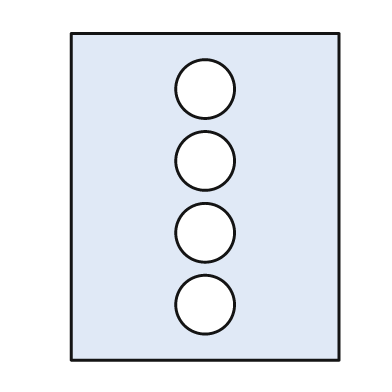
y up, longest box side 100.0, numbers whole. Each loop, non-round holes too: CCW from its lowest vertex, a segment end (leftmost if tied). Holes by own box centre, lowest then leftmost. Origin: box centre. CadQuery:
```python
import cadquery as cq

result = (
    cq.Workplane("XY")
    .moveTo(-41.0, -50.0)
    .lineTo(41.0, -50.0)
    .lineTo(41.0, 50.0)
    .lineTo(-41.0, 50.0)
    .close()
    .moveTo(0.0, -33.0)
    .circle(9.0)
    .moveTo(0.0, -11.0)
    .circle(9.0)
    .moveTo(0.0, 11.0)
    .circle(9.0)
    .moveTo(0.0, 33.0)
    .circle(9.0)
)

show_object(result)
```